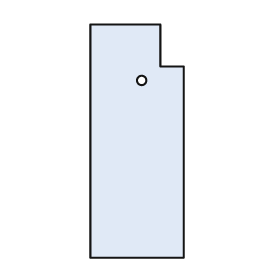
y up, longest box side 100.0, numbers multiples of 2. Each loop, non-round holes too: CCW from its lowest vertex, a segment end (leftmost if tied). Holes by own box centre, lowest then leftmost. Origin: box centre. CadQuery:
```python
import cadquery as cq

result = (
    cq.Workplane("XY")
    .moveTo(-20.0, -50.0)
    .lineTo(20.0, -50.0)
    .lineTo(20.0, 32.0)
    .lineTo(10.0, 32.0)
    .lineTo(10.0, 50.0)
    .lineTo(-20.0, 50.0)
    .close()
    .moveTo(2.0, 26.0)
    .circle(2.0)
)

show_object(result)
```